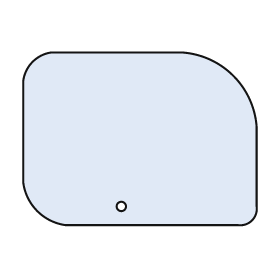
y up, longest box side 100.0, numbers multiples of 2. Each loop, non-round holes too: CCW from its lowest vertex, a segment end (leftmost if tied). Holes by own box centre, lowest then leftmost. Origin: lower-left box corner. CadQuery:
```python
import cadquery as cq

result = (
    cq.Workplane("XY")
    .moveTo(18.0, 0.0)
    .lineTo(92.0, 0.0)
    .threePointArc((98.0, 2.0), (100.0, 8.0))
    .lineTo(100.0, 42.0)
    .threePointArc((90.0, 64.0), (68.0, 74.0))
    .lineTo(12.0, 74.0)
    .threePointArc((4.0, 70.0), (0.0, 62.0))
    .lineTo(0.0, 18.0)
    .threePointArc((6.0, 6.0), (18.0, 0.0))
    .close()
    .moveTo(42.0, 8.0)
    .circle(2.0)
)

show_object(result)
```